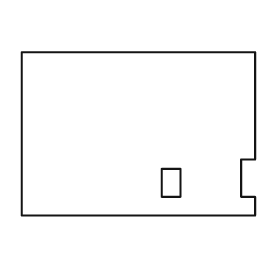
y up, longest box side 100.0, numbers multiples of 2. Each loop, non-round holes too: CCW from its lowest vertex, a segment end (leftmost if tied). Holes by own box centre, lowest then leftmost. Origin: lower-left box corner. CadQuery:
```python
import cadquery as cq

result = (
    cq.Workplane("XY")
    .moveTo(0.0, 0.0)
    .lineTo(100.0, 0.0)
    .lineTo(100.0, 8.0)
    .lineTo(94.0, 8.0)
    .lineTo(94.0, 24.0)
    .lineTo(100.0, 24.0)
    .lineTo(100.0, 70.0)
    .lineTo(0.0, 70.0)
    .close()
    .moveTo(60.0, 8.0)
    .lineTo(68.0, 8.0)
    .lineTo(68.0, 20.0)
    .lineTo(60.0, 20.0)
    .close()
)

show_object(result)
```